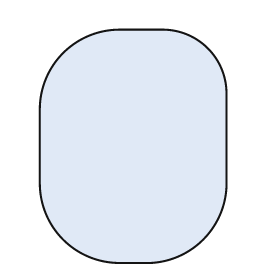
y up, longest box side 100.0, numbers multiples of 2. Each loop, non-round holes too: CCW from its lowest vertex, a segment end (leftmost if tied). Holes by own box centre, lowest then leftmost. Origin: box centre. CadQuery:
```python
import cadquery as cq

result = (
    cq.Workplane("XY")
    .moveTo(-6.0, -50.0)
    .lineTo(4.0, -50.0)
    .threePointArc((30.0, -40.0), (40.0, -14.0))
    .lineTo(40.0, 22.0)
    .threePointArc((32.0, 42.0), (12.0, 50.0))
    .lineTo(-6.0, 50.0)
    .threePointArc((-30.0, 40.0), (-40.0, 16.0))
    .lineTo(-40.0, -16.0)
    .threePointArc((-30.0, -40.0), (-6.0, -50.0))
    .close()
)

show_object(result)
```